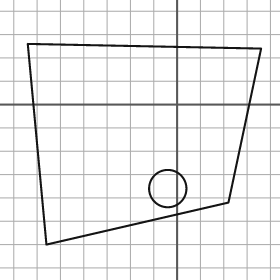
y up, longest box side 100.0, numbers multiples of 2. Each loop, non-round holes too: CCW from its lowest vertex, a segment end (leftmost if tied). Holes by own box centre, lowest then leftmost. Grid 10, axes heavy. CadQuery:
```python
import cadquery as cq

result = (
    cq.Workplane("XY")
    .moveTo(-56.0, -60.0)
    .lineTo(22.0, -42.0)
    .lineTo(36.0, 24.0)
    .lineTo(-64.0, 26.0)
    .close()
    .moveTo(-4.0, -36.0)
    .circle(8.0)
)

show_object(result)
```